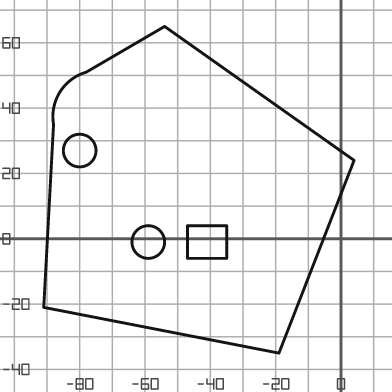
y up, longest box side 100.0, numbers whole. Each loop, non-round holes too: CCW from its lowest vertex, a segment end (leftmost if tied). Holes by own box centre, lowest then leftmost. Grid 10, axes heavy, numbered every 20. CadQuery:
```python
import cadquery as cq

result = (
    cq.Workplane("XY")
    .moveTo(-19.0, -35.0)
    .lineTo(4.0, 24.0)
    .lineTo(-54.0, 65.0)
    .lineTo(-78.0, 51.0)
    .threePointArc((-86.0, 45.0), (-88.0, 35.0))
    .lineTo(-91.0, -21.0)
    .close()
    .moveTo(-59.0, -1.0)
    .circle(5.0)
    .moveTo(-47.0, -6.0)
    .lineTo(-35.0, -6.0)
    .lineTo(-35.0, 4.0)
    .lineTo(-47.0, 4.0)
    .close()
    .moveTo(-80.0, 27.0)
    .circle(5.0)
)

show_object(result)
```